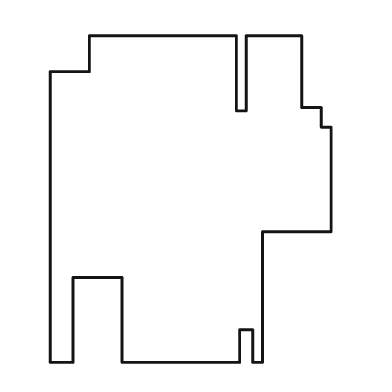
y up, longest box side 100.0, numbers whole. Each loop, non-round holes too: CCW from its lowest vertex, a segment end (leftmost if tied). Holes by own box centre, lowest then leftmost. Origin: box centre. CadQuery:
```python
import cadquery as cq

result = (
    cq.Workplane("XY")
    .moveTo(-43.0, -50.0)
    .lineTo(-36.0, -50.0)
    .lineTo(-36.0, -24.0)
    .lineTo(-21.0, -24.0)
    .lineTo(-21.0, -50.0)
    .lineTo(15.0, -50.0)
    .lineTo(15.0, -40.0)
    .lineTo(19.0, -40.0)
    .lineTo(19.0, -50.0)
    .lineTo(22.0, -50.0)
    .lineTo(22.0, -10.0)
    .lineTo(43.0, -10.0)
    .lineTo(43.0, 22.0)
    .lineTo(40.0, 22.0)
    .lineTo(40.0, 28.0)
    .lineTo(34.0, 28.0)
    .lineTo(34.0, 50.0)
    .lineTo(17.0, 50.0)
    .lineTo(17.0, 27.0)
    .lineTo(14.0, 27.0)
    .lineTo(14.0, 50.0)
    .lineTo(-31.0, 50.0)
    .lineTo(-31.0, 39.0)
    .lineTo(-43.0, 39.0)
    .close()
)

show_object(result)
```